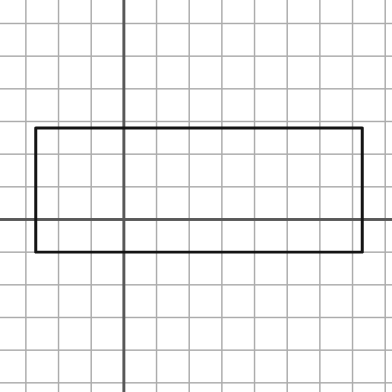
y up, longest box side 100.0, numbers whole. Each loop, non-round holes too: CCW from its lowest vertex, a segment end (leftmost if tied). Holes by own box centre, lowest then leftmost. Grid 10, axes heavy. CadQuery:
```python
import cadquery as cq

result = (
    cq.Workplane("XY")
    .moveTo(-27.0, -10.0)
    .lineTo(73.0, -10.0)
    .lineTo(73.0, 28.0)
    .lineTo(-27.0, 28.0)
    .close()
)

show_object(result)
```